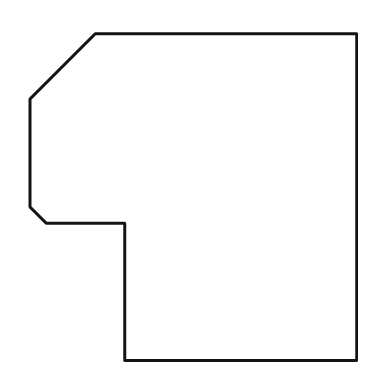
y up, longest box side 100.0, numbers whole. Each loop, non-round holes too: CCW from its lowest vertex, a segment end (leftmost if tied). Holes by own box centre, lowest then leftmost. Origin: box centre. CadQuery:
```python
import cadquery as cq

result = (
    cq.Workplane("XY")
    .moveTo(-21.0, -50.0)
    .lineTo(50.0, -50.0)
    .lineTo(50.0, 50.0)
    .lineTo(-30.0, 50.0)
    .lineTo(-50.0, 30.0)
    .lineTo(-50.0, -3.0)
    .lineTo(-45.0, -8.0)
    .lineTo(-21.0, -8.0)
    .close()
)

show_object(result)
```